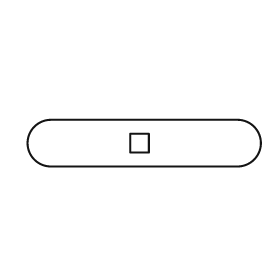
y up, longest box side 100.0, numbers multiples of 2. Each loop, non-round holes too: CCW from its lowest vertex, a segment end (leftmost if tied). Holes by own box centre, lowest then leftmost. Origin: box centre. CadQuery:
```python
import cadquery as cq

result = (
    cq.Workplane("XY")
    .moveTo(-40.0, -10.0)
    .lineTo(40.0, -10.0)
    .threePointArc((50.0, 0.0), (40.0, 10.0))
    .lineTo(-40.0, 10.0)
    .threePointArc((-50.0, 0.0), (-40.0, -10.0))
    .close()
    .moveTo(-6.0, -4.0)
    .lineTo(2.0, -4.0)
    .lineTo(2.0, 4.0)
    .lineTo(-6.0, 4.0)
    .close()
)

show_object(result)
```